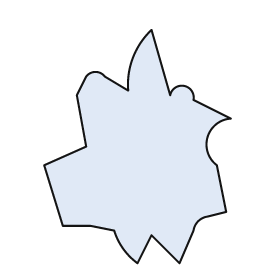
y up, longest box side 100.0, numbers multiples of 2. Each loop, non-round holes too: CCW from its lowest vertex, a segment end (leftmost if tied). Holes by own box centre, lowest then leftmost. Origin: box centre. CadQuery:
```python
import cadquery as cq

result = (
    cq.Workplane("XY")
    .moveTo(0.0, -50.0)
    .lineTo(6.0, -38.0)
    .lineTo(18.0, -50.0)
    .lineTo(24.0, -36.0)
    .threePointArc((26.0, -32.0), (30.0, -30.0))
    .lineTo(38.0, -28.0)
    .lineTo(34.0, -8.0)
    .threePointArc((30.0, 4.0), (40.0, 12.0))
    .lineTo(24.0, 20.0)
    .threePointArc((20.0, 26.0), (14.0, 22.0))
    .lineTo(6.0, 50.0)
    .threePointArc((-2.0, 38.0), (-4.0, 24.0))
    .lineTo(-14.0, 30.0)
    .threePointArc((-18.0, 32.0), (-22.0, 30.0))
    .lineTo(-26.0, 22.0)
    .lineTo(-22.0, 0.0)
    .lineTo(-40.0, -8.0)
    .lineTo(-32.0, -34.0)
    .lineTo(-20.0, -34.0)
    .lineTo(-10.0, -36.0)
    .threePointArc((-6.0, -44.0), (0.0, -50.0))
    .close()
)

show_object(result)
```